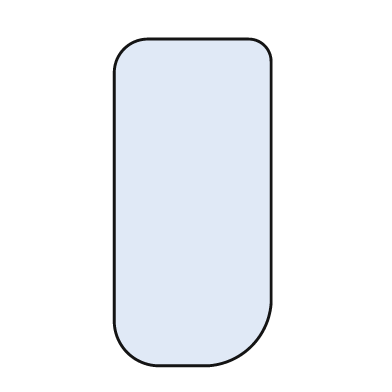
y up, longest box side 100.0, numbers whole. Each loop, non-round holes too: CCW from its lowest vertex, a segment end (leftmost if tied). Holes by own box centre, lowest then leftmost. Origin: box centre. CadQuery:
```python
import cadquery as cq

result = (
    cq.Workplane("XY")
    .moveTo(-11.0, -50.0)
    .lineTo(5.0, -50.0)
    .threePointArc((18.0, -44.0), (24.0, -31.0))
    .lineTo(24.0, 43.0)
    .threePointArc((22.0, 48.0), (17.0, 50.0))
    .lineTo(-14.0, 50.0)
    .threePointArc((-21.0, 47.0), (-24.0, 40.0))
    .lineTo(-24.0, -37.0)
    .threePointArc((-20.0, -46.0), (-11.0, -50.0))
    .close()
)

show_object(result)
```